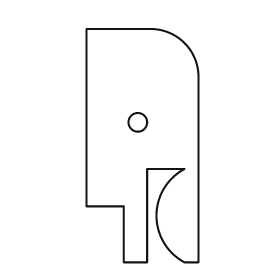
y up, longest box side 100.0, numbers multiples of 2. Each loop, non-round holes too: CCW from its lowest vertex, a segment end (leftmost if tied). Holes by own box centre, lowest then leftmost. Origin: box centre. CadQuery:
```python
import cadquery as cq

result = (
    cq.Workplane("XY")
    .moveTo(-8.0, -50.0)
    .lineTo(2.0, -50.0)
    .lineTo(2.0, -10.0)
    .lineTo(18.0, -10.0)
    .threePointArc((6.0, -30.0), (18.0, -50.0))
    .lineTo(24.0, -50.0)
    .lineTo(24.0, 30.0)
    .threePointArc((18.0, 44.0), (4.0, 50.0))
    .lineTo(-24.0, 50.0)
    .lineTo(-24.0, -26.0)
    .lineTo(-8.0, -26.0)
    .close()
    .moveTo(-2.0, 10.0)
    .circle(4.0)
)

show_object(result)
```